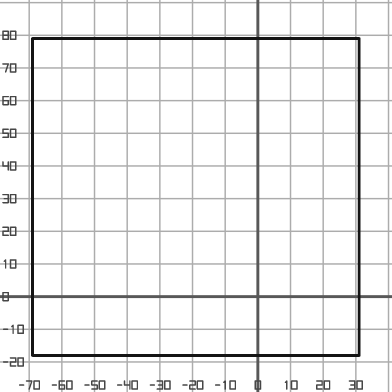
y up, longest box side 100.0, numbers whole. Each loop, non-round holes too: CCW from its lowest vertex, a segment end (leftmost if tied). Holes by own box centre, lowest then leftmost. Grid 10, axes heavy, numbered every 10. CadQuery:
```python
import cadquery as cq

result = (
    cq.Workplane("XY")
    .moveTo(-69.0, -18.0)
    .lineTo(31.0, -18.0)
    .lineTo(31.0, 79.0)
    .lineTo(-69.0, 79.0)
    .close()
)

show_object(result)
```